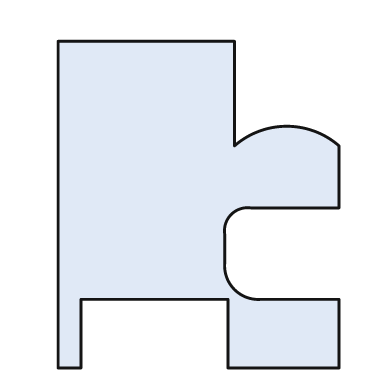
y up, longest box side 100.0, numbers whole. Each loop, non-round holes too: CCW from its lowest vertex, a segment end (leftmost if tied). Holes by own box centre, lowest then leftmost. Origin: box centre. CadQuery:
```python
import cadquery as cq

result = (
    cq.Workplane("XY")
    .moveTo(-43.0, -50.0)
    .lineTo(-36.0, -50.0)
    .lineTo(-36.0, -29.0)
    .lineTo(9.0, -29.0)
    .lineTo(9.0, -50.0)
    .lineTo(43.0, -50.0)
    .lineTo(43.0, -29.0)
    .lineTo(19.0, -29.0)
    .threePointArc((11.0, -26.0), (8.0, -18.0))
    .lineTo(8.0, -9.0)
    .threePointArc((10.0, -3.0), (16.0, -1.0))
    .lineTo(43.0, -1.0)
    .lineTo(43.0, 18.0)
    .threePointArc((27.0, 24.0), (11.0, 18.0))
    .lineTo(11.0, 50.0)
    .lineTo(-43.0, 50.0)
    .close()
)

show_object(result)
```